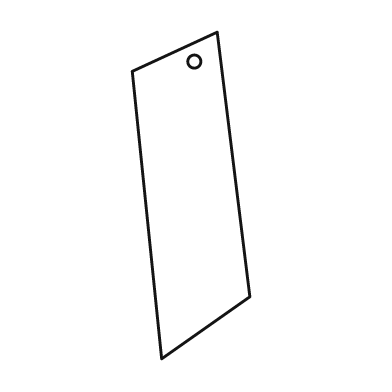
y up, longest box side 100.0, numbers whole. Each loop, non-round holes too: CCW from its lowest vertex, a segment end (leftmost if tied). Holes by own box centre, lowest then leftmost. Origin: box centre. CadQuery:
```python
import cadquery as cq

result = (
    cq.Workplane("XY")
    .moveTo(-9.0, -50.0)
    .lineTo(18.0, -31.0)
    .lineTo(8.0, 50.0)
    .lineTo(-18.0, 38.0)
    .close()
    .moveTo(1.0, 41.0)
    .circle(2.0)
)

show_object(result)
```